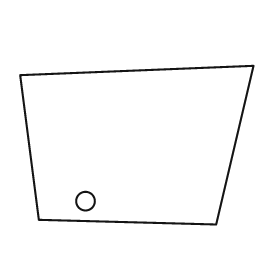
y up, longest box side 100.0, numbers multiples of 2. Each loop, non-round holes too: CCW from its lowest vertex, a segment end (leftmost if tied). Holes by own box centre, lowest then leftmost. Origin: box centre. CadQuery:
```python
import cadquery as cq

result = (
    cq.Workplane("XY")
    .moveTo(34.0, -34.0)
    .lineTo(50.0, 34.0)
    .lineTo(-50.0, 30.0)
    .lineTo(-42.0, -32.0)
    .close()
    .moveTo(-22.0, -24.0)
    .circle(4.0)
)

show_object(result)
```